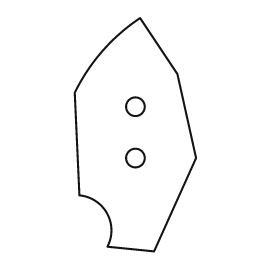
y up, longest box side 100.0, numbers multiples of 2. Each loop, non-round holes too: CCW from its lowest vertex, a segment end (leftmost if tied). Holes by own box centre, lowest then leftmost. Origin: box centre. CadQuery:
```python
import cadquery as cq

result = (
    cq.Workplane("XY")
    .moveTo(8.0, -50.0)
    .lineTo(26.0, -10.0)
    .lineTo(18.0, 26.0)
    .lineTo(2.0, 50.0)
    .threePointArc((-14.0, 36.0), (-26.0, 18.0))
    .lineTo(-24.0, -26.0)
    .threePointArc((-12.0, -34.0), (-12.0, -48.0))
    .close()
    .moveTo(0.0, -10.0)
    .circle(4.0)
    .moveTo(0.0, 12.0)
    .circle(4.0)
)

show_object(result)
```